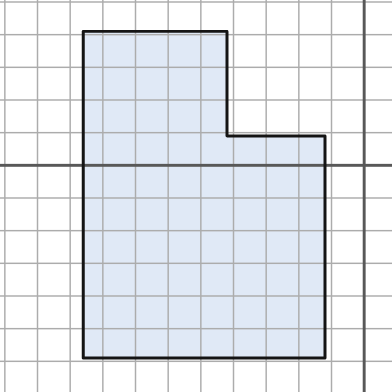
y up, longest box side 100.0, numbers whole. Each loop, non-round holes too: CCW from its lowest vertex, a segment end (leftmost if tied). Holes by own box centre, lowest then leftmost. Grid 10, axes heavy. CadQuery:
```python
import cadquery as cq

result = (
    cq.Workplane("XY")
    .moveTo(-86.0, -59.0)
    .lineTo(-12.0, -59.0)
    .lineTo(-12.0, 9.0)
    .lineTo(-42.0, 9.0)
    .lineTo(-42.0, 41.0)
    .lineTo(-86.0, 41.0)
    .close()
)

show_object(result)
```